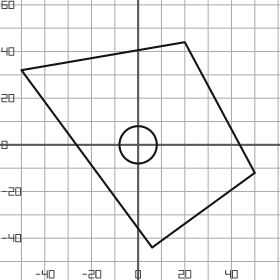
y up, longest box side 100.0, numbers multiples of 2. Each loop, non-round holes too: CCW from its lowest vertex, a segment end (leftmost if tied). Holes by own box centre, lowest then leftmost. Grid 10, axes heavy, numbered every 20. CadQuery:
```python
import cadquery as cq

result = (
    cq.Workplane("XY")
    .moveTo(6.0, -44.0)
    .lineTo(50.0, -12.0)
    .lineTo(20.0, 44.0)
    .lineTo(-50.0, 32.0)
    .close()
    .moveTo(0.0, 0.0)
    .circle(8.0)
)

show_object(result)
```